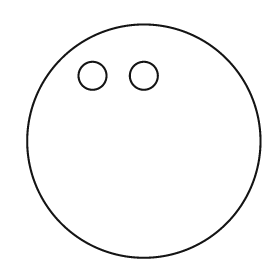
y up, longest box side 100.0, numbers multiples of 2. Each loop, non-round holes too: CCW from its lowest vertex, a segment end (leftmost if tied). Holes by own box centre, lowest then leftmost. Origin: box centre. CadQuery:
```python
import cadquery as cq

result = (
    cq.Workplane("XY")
    .moveTo(0.0, 0.0)
    .circle(50.0)
    .moveTo(-22.0, 28.0)
    .circle(6.0)
    .moveTo(0.0, 28.0)
    .circle(6.0)
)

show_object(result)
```